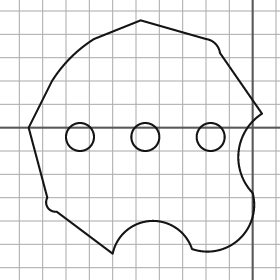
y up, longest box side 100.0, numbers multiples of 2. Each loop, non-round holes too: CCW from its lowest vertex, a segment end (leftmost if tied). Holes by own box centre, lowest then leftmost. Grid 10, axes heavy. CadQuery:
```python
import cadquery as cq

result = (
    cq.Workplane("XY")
    .moveTo(-60.0, -54.0)
    .threePointArc((-44.0, -40.0), (-26.0, -52.0))
    .threePointArc((-6.0, -48.0), (0.0, -28.0))
    .threePointArc((-6.0, -10.0), (4.0, 6.0))
    .lineTo(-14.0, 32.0)
    .threePointArc((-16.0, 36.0), (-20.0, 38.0))
    .lineTo(-48.0, 46.0)
    .lineTo(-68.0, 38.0)
    .threePointArc((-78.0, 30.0), (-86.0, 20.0))
    .lineTo(-96.0, 0.0)
    .lineTo(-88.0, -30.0)
    .threePointArc((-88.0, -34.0), (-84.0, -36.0))
    .close()
    .moveTo(-74.0, -4.0)
    .circle(6.0)
    .moveTo(-46.0, -4.0)
    .circle(6.0)
    .moveTo(-18.0, -4.0)
    .circle(6.0)
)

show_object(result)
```